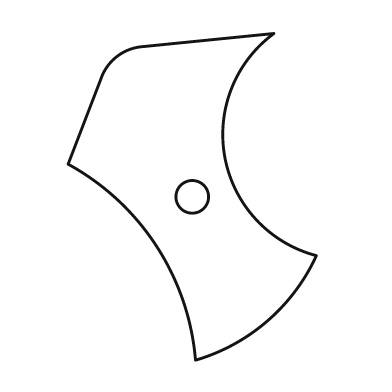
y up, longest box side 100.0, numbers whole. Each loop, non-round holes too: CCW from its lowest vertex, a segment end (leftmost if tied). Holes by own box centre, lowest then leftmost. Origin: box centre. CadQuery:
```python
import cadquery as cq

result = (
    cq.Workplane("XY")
    .moveTo(1.0, -50.0)
    .threePointArc((23.0, -38.0), (38.0, -18.0))
    .threePointArc((10.0, 12.0), (25.0, 50.0))
    .lineTo(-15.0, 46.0)
    .threePointArc((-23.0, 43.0), (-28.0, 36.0))
    .lineTo(-38.0, 10.0)
    .threePointArc((-11.0, -15.0), (1.0, -50.0))
    .close()
    .moveTo(0.0, 0.0)
    .circle(5.0)
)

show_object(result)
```